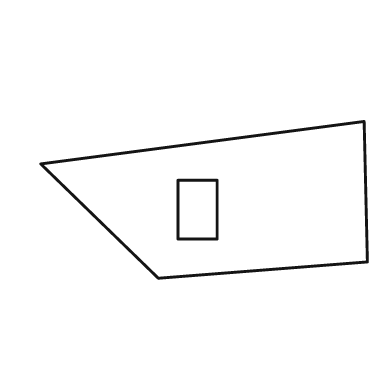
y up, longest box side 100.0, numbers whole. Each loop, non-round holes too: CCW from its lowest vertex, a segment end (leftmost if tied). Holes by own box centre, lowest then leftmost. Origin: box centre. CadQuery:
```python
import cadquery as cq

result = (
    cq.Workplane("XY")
    .moveTo(-14.0, -24.0)
    .lineTo(50.0, -19.0)
    .lineTo(49.0, 24.0)
    .lineTo(-50.0, 11.0)
    .close()
    .moveTo(-8.0, -12.0)
    .lineTo(4.0, -12.0)
    .lineTo(4.0, 6.0)
    .lineTo(-8.0, 6.0)
    .close()
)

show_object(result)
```